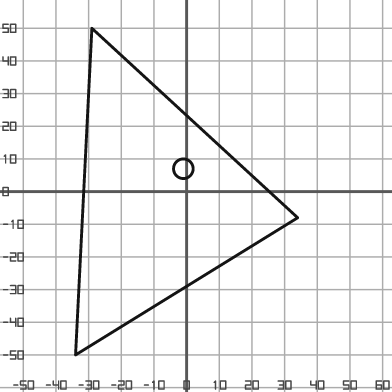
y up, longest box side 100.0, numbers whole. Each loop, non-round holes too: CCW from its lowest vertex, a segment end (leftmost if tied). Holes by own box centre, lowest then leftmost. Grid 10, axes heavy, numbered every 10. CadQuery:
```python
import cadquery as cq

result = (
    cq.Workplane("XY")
    .moveTo(-34.0, -50.0)
    .lineTo(34.0, -8.0)
    .lineTo(-29.0, 50.0)
    .close()
    .moveTo(-1.0, 7.0)
    .circle(3.0)
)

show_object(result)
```